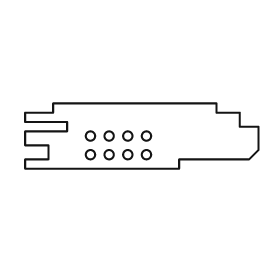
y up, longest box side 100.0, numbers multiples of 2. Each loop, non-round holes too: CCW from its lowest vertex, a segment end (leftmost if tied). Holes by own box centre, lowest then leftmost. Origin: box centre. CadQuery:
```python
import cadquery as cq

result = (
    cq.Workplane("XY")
    .moveTo(-50.0, -14.0)
    .lineTo(16.0, -14.0)
    .lineTo(16.0, -10.0)
    .lineTo(46.0, -10.0)
    .lineTo(50.0, -6.0)
    .lineTo(50.0, 4.0)
    .lineTo(42.0, 4.0)
    .lineTo(42.0, 10.0)
    .lineTo(32.0, 10.0)
    .lineTo(32.0, 14.0)
    .lineTo(-38.0, 14.0)
    .lineTo(-38.0, 10.0)
    .lineTo(-50.0, 10.0)
    .lineTo(-50.0, 6.0)
    .lineTo(-32.0, 6.0)
    .lineTo(-32.0, 2.0)
    .lineTo(-50.0, 2.0)
    .lineTo(-50.0, -4.0)
    .lineTo(-40.0, -4.0)
    .lineTo(-40.0, -10.0)
    .lineTo(-50.0, -10.0)
    .close()
    .moveTo(-22.0, -8.0)
    .circle(2.0)
    .moveTo(-14.0, -8.0)
    .circle(2.0)
    .moveTo(-6.0, -8.0)
    .circle(2.0)
    .moveTo(2.0, -8.0)
    .circle(2.0)
    .moveTo(-22.0, 0.0)
    .circle(2.0)
    .moveTo(-14.0, 0.0)
    .circle(2.0)
    .moveTo(-6.0, 0.0)
    .circle(2.0)
    .moveTo(2.0, 0.0)
    .circle(2.0)
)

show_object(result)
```